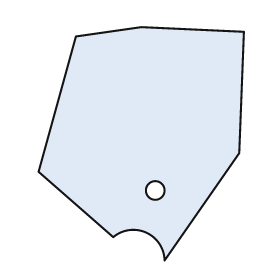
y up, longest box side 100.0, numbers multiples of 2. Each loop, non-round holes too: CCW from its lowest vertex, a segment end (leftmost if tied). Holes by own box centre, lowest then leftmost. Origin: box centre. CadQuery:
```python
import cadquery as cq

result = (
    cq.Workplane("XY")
    .moveTo(10.0, -50.0)
    .lineTo(42.0, -4.0)
    .lineTo(44.0, 48.0)
    .lineTo(0.0, 50.0)
    .lineTo(-28.0, 46.0)
    .lineTo(-44.0, -12.0)
    .lineTo(-12.0, -40.0)
    .threePointArc((2.0, -38.0), (10.0, -50.0))
    .close()
    .moveTo(6.0, -20.0)
    .circle(4.0)
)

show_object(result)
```